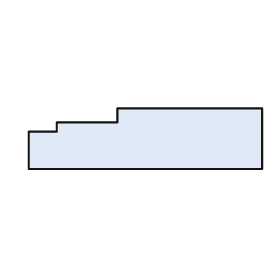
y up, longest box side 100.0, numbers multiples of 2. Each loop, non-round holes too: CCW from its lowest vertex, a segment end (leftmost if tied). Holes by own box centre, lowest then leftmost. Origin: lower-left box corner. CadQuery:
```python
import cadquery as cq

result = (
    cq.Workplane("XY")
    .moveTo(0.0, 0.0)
    .lineTo(100.0, 0.0)
    .lineTo(100.0, 26.0)
    .lineTo(38.0, 26.0)
    .lineTo(38.0, 20.0)
    .lineTo(12.0, 20.0)
    .lineTo(12.0, 16.0)
    .lineTo(0.0, 16.0)
    .close()
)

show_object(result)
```